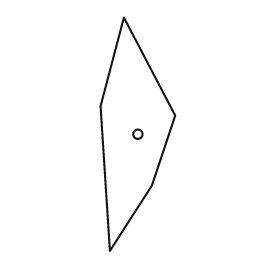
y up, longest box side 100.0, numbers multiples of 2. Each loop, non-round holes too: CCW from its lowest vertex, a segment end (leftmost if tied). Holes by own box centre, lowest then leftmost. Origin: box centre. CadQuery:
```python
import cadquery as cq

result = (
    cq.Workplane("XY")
    .moveTo(-12.0, -50.0)
    .lineTo(6.0, -22.0)
    .lineTo(16.0, 8.0)
    .lineTo(-6.0, 50.0)
    .lineTo(-16.0, 12.0)
    .close()
    .moveTo(0.0, 0.0)
    .circle(2.0)
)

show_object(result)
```